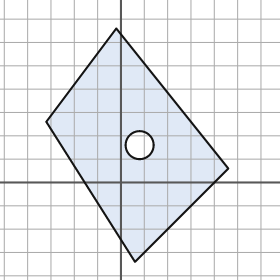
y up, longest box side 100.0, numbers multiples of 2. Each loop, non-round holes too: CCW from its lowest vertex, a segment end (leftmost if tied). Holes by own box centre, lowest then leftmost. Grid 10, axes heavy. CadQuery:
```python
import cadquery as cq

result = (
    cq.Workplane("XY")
    .moveTo(6.0, -34.0)
    .lineTo(46.0, 6.0)
    .lineTo(-2.0, 66.0)
    .lineTo(-32.0, 26.0)
    .close()
    .moveTo(8.0, 16.0)
    .circle(6.0)
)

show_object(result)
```